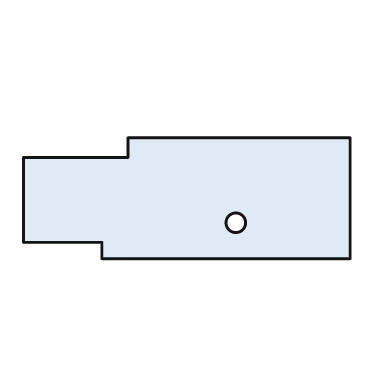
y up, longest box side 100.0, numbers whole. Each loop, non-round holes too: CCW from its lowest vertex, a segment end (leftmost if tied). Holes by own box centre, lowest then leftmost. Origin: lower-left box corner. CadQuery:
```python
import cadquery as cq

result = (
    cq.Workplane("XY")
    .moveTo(24.0, 0.0)
    .lineTo(100.0, 0.0)
    .lineTo(100.0, 37.0)
    .lineTo(32.0, 37.0)
    .lineTo(32.0, 31.0)
    .lineTo(0.0, 31.0)
    .lineTo(0.0, 5.0)
    .lineTo(24.0, 5.0)
    .close()
    .moveTo(65.0, 11.0)
    .circle(3.0)
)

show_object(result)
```